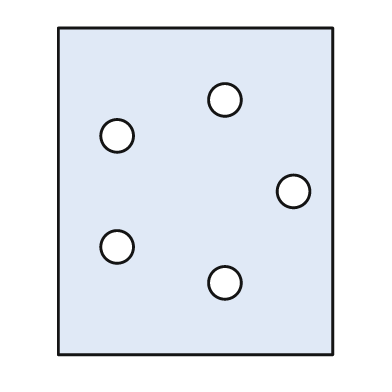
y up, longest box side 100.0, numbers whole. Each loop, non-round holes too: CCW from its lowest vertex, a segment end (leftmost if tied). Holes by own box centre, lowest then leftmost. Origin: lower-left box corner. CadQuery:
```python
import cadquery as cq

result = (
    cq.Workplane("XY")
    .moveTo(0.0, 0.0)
    .lineTo(84.0, 0.0)
    .lineTo(84.0, 100.0)
    .lineTo(0.0, 100.0)
    .close()
    .moveTo(51.0, 22.0)
    .circle(5.0)
    .moveTo(18.0, 33.0)
    .circle(5.0)
    .moveTo(72.0, 50.0)
    .circle(5.0)
    .moveTo(18.0, 67.0)
    .circle(5.0)
    .moveTo(51.0, 78.0)
    .circle(5.0)
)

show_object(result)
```